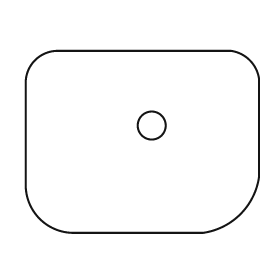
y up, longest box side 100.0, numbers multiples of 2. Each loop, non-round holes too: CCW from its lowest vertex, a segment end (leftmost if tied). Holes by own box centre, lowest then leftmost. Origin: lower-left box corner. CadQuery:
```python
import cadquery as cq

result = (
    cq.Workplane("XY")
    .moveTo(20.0, 0.0)
    .lineTo(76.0, 0.0)
    .threePointArc((92.0, 8.0), (100.0, 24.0))
    .lineTo(100.0, 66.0)
    .threePointArc((96.0, 74.0), (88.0, 78.0))
    .lineTo(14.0, 78.0)
    .threePointArc((4.0, 74.0), (0.0, 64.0))
    .lineTo(0.0, 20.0)
    .threePointArc((6.0, 6.0), (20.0, 0.0))
    .close()
    .moveTo(54.0, 46.0)
    .circle(6.0)
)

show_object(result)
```